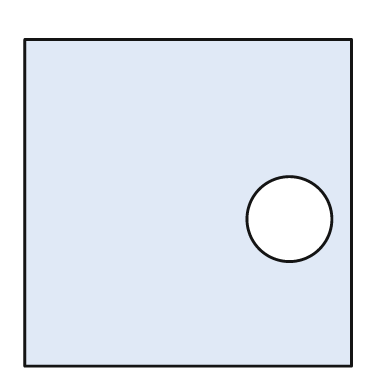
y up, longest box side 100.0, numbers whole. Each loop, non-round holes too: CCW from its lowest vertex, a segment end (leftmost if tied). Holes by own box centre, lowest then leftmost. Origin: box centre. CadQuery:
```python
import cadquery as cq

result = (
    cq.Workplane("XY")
    .moveTo(-50.0, -50.0)
    .lineTo(50.0, -50.0)
    .lineTo(50.0, 50.0)
    .lineTo(-50.0, 50.0)
    .close()
    .moveTo(31.0, -5.0)
    .circle(13.0)
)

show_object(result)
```